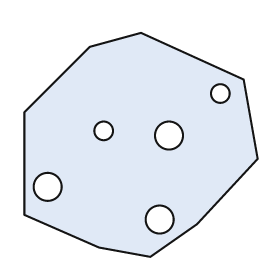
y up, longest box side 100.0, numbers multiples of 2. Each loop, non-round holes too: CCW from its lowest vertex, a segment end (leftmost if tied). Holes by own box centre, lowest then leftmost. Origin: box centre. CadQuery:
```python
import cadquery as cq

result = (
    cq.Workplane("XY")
    .moveTo(4.0, -48.0)
    .lineTo(24.0, -34.0)
    .lineTo(50.0, -6.0)
    .lineTo(44.0, 28.0)
    .lineTo(0.0, 48.0)
    .lineTo(-22.0, 42.0)
    .lineTo(-50.0, 14.0)
    .lineTo(-50.0, -30.0)
    .lineTo(-18.0, -44.0)
    .close()
    .moveTo(8.0, -32.0)
    .circle(6.0)
    .moveTo(-40.0, -18.0)
    .circle(6.0)
    .moveTo(12.0, 4.0)
    .circle(6.0)
    .moveTo(-16.0, 6.0)
    .circle(4.0)
    .moveTo(34.0, 22.0)
    .circle(4.0)
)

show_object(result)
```